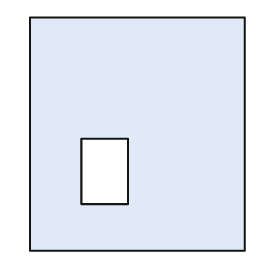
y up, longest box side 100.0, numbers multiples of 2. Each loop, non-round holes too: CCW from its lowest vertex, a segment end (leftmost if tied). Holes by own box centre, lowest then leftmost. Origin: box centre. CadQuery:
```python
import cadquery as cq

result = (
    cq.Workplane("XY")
    .moveTo(-46.0, -50.0)
    .lineTo(46.0, -50.0)
    .lineTo(46.0, 50.0)
    .lineTo(-46.0, 50.0)
    .close()
    .moveTo(-24.0, -30.0)
    .lineTo(-4.0, -30.0)
    .lineTo(-4.0, -2.0)
    .lineTo(-24.0, -2.0)
    .close()
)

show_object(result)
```